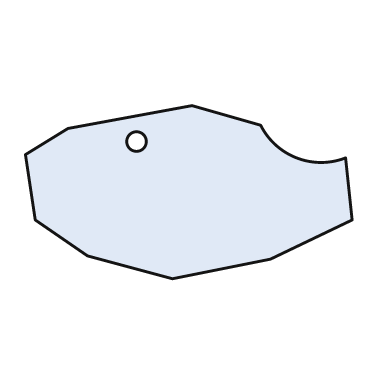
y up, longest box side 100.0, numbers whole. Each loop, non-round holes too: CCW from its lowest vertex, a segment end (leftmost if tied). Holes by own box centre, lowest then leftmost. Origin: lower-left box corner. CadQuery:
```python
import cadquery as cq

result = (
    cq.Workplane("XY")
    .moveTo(45.0, 0.0)
    .lineTo(75.0, 6.0)
    .lineTo(100.0, 18.0)
    .lineTo(98.0, 37.0)
    .threePointArc((83.0, 37.0), (72.0, 47.0))
    .lineTo(51.0, 53.0)
    .lineTo(13.0, 46.0)
    .lineTo(0.0, 38.0)
    .lineTo(3.0, 18.0)
    .lineTo(19.0, 7.0)
    .close()
    .moveTo(34.0, 42.0)
    .circle(3.0)
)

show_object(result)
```